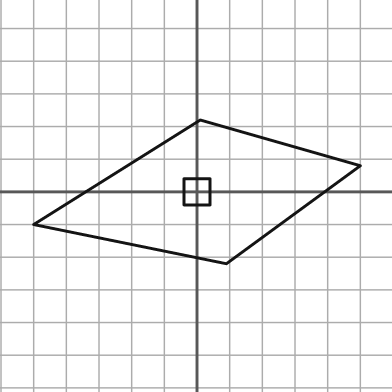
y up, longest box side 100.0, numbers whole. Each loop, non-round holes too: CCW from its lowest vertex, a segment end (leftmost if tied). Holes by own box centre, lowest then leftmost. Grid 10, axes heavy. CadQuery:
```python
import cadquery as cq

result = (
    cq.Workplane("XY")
    .moveTo(9.0, -22.0)
    .lineTo(50.0, 8.0)
    .lineTo(1.0, 22.0)
    .lineTo(-50.0, -10.0)
    .close()
    .moveTo(-4.0, -4.0)
    .lineTo(4.0, -4.0)
    .lineTo(4.0, 4.0)
    .lineTo(-4.0, 4.0)
    .close()
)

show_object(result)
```